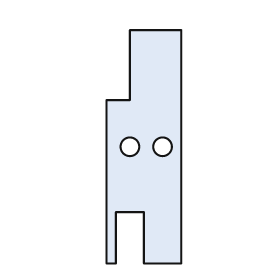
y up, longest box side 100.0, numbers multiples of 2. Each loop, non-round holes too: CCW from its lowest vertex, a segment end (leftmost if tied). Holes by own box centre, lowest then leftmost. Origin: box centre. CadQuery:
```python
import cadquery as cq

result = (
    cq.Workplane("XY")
    .moveTo(-16.0, -50.0)
    .lineTo(-12.0, -50.0)
    .lineTo(-12.0, -28.0)
    .lineTo(0.0, -28.0)
    .lineTo(0.0, -50.0)
    .lineTo(16.0, -50.0)
    .lineTo(16.0, 50.0)
    .lineTo(-6.0, 50.0)
    .lineTo(-6.0, 20.0)
    .lineTo(-16.0, 20.0)
    .close()
    .moveTo(-6.0, 0.0)
    .circle(4.0)
    .moveTo(8.0, 0.0)
    .circle(4.0)
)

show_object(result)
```